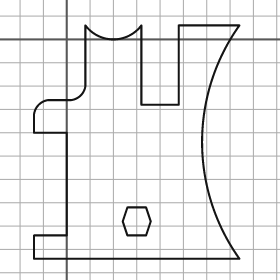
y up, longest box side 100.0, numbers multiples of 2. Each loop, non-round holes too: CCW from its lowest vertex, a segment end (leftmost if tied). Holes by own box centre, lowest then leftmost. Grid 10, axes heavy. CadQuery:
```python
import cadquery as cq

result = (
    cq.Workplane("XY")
    .moveTo(-14.0, -94.0)
    .lineTo(74.0, -94.0)
    .threePointArc((58.0, -44.0), (74.0, 6.0))
    .lineTo(48.0, 6.0)
    .lineTo(48.0, -28.0)
    .lineTo(32.0, -28.0)
    .lineTo(32.0, 6.0)
    .threePointArc((20.0, 0.0), (8.0, 6.0))
    .lineTo(8.0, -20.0)
    .threePointArc((6.0, -24.0), (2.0, -26.0))
    .lineTo(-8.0, -26.0)
    .threePointArc((-12.0, -28.0), (-14.0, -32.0))
    .lineTo(-14.0, -40.0)
    .lineTo(0.0, -40.0)
    .lineTo(0.0, -84.0)
    .lineTo(-14.0, -84.0)
    .close()
    .moveTo(26.0, -84.0)
    .lineTo(34.0, -84.0)
    .lineTo(36.0, -78.0)
    .lineTo(34.0, -72.0)
    .lineTo(26.0, -72.0)
    .lineTo(24.0, -78.0)
    .close()
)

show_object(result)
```